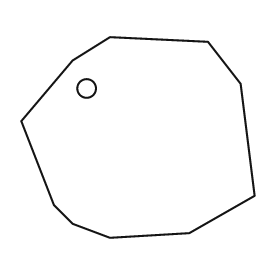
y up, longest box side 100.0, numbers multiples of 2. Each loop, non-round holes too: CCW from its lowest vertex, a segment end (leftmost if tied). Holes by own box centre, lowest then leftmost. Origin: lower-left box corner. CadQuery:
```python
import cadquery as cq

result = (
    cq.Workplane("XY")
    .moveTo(38.0, 0.0)
    .lineTo(72.0, 2.0)
    .lineTo(100.0, 18.0)
    .lineTo(94.0, 66.0)
    .lineTo(80.0, 84.0)
    .lineTo(38.0, 86.0)
    .lineTo(22.0, 76.0)
    .lineTo(0.0, 50.0)
    .lineTo(14.0, 14.0)
    .lineTo(22.0, 6.0)
    .close()
    .moveTo(28.0, 64.0)
    .circle(4.0)
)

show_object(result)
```